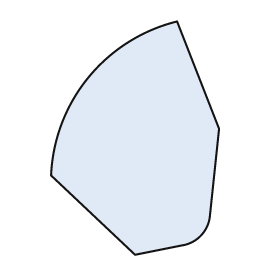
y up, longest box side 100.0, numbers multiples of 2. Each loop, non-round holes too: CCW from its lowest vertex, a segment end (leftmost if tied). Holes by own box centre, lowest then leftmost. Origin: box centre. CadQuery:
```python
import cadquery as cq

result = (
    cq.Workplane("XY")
    .moveTo(0.0, -50.0)
    .lineTo(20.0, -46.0)
    .threePointArc((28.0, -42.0), (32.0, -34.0))
    .lineTo(36.0, 4.0)
    .lineTo(18.0, 50.0)
    .threePointArc((-20.0, 26.0), (-36.0, -16.0))
    .close()
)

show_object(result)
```